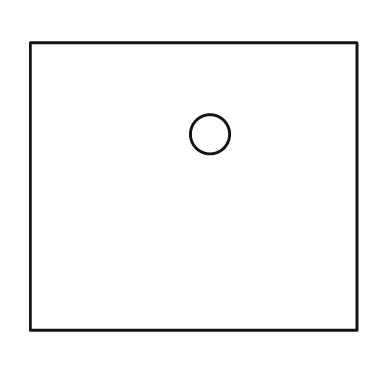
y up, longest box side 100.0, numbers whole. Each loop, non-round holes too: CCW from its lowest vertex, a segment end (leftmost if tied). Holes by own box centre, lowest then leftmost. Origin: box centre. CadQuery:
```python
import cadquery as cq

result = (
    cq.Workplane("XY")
    .moveTo(-50.0, -44.0)
    .lineTo(50.0, -44.0)
    .lineTo(50.0, 44.0)
    .lineTo(-50.0, 44.0)
    .close()
    .moveTo(5.0, 16.0)
    .circle(6.0)
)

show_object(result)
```